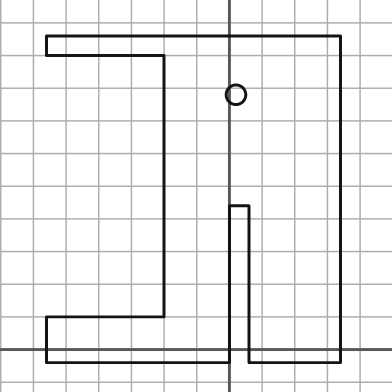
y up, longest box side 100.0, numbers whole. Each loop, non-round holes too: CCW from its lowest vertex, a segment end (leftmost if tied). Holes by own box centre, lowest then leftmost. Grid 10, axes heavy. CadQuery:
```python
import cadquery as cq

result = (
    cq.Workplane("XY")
    .moveTo(-56.0, -4.0)
    .lineTo(0.0, -4.0)
    .lineTo(0.0, 44.0)
    .lineTo(6.0, 44.0)
    .lineTo(6.0, -4.0)
    .lineTo(34.0, -4.0)
    .lineTo(34.0, 96.0)
    .lineTo(-56.0, 96.0)
    .lineTo(-56.0, 90.0)
    .lineTo(-20.0, 90.0)
    .lineTo(-20.0, 10.0)
    .lineTo(-56.0, 10.0)
    .close()
    .moveTo(2.0, 78.0)
    .circle(3.0)
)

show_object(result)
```